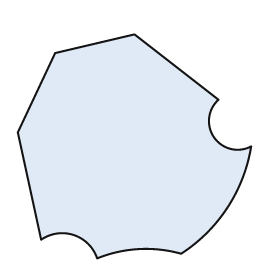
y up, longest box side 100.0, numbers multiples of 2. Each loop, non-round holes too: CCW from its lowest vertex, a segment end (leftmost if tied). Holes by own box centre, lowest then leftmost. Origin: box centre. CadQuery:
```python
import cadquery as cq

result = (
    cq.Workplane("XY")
    .moveTo(-16.0, -48.0)
    .threePointArc((2.0, -44.0), (20.0, -46.0))
    .threePointArc((40.0, -26.0), (50.0, 0.0))
    .threePointArc((34.0, 4.0), (36.0, 20.0))
    .lineTo(0.0, 48.0)
    .lineTo(-34.0, 40.0)
    .lineTo(-50.0, 6.0)
    .lineTo(-40.0, -40.0)
    .threePointArc((-26.0, -38.0), (-16.0, -48.0))
    .close()
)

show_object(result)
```